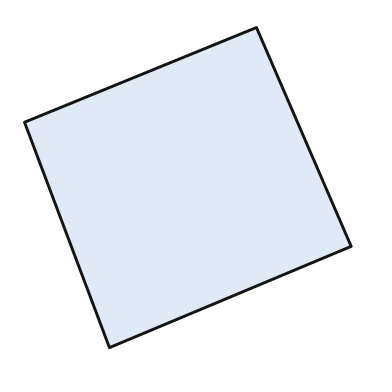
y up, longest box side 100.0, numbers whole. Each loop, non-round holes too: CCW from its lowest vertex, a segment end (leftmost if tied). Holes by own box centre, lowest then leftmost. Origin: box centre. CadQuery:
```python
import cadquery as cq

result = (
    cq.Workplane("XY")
    .moveTo(-24.0, -49.0)
    .lineTo(50.0, -18.0)
    .lineTo(21.0, 49.0)
    .lineTo(-50.0, 20.0)
    .close()
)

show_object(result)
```